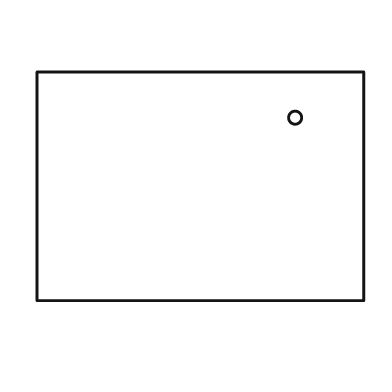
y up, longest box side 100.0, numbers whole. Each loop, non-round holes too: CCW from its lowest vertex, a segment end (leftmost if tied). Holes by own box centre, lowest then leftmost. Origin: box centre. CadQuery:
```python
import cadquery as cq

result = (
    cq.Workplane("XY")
    .moveTo(-50.0, -35.0)
    .lineTo(50.0, -35.0)
    .lineTo(50.0, 35.0)
    .lineTo(-50.0, 35.0)
    .close()
    .moveTo(29.0, 21.0)
    .circle(2.0)
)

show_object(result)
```